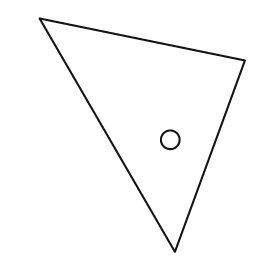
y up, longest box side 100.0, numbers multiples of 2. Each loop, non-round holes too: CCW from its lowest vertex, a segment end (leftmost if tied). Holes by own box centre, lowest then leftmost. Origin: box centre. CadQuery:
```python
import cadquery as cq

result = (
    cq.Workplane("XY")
    .moveTo(14.0, -50.0)
    .lineTo(44.0, 32.0)
    .lineTo(-44.0, 50.0)
    .close()
    .moveTo(12.0, -2.0)
    .circle(4.0)
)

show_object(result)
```